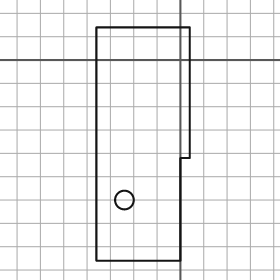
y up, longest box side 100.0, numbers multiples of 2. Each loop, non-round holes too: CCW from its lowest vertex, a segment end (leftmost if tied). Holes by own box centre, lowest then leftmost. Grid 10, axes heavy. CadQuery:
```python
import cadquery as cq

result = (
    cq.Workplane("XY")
    .moveTo(-36.0, -86.0)
    .lineTo(0.0, -86.0)
    .lineTo(0.0, -42.0)
    .lineTo(4.0, -42.0)
    .lineTo(4.0, 14.0)
    .lineTo(-36.0, 14.0)
    .close()
    .moveTo(-24.0, -60.0)
    .circle(4.0)
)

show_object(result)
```